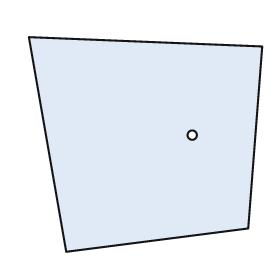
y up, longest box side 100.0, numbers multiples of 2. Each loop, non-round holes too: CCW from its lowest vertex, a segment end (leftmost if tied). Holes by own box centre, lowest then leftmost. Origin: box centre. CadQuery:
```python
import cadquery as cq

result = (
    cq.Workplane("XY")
    .moveTo(-34.0, -46.0)
    .lineTo(44.0, -36.0)
    .lineTo(50.0, 42.0)
    .lineTo(-50.0, 46.0)
    .close()
    .moveTo(20.0, 4.0)
    .circle(2.0)
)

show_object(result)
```